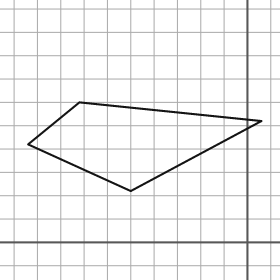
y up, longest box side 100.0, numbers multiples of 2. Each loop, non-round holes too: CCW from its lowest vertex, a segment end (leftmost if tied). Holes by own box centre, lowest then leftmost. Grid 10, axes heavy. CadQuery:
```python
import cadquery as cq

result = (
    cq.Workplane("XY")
    .moveTo(-50.0, 22.0)
    .lineTo(6.0, 52.0)
    .lineTo(-72.0, 60.0)
    .lineTo(-94.0, 42.0)
    .close()
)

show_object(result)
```